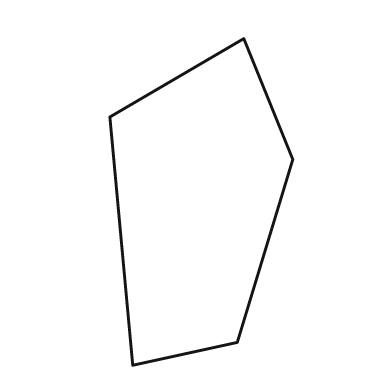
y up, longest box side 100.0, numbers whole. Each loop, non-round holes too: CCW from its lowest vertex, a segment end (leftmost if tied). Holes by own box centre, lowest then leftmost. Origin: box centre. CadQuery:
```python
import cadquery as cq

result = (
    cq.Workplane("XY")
    .moveTo(-21.0, -50.0)
    .lineTo(11.0, -43.0)
    .lineTo(28.0, 13.0)
    .lineTo(13.0, 50.0)
    .lineTo(-28.0, 26.0)
    .close()
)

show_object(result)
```